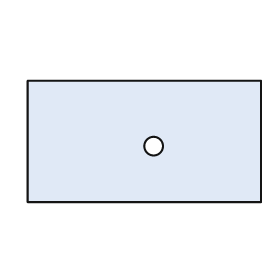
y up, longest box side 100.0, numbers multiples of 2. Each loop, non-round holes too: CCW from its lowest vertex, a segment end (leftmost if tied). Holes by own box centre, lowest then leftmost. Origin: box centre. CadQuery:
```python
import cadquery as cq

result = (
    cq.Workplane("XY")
    .moveTo(-50.0, -26.0)
    .lineTo(50.0, -26.0)
    .lineTo(50.0, 26.0)
    .lineTo(-50.0, 26.0)
    .close()
    .moveTo(4.0, -2.0)
    .circle(4.0)
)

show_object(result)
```